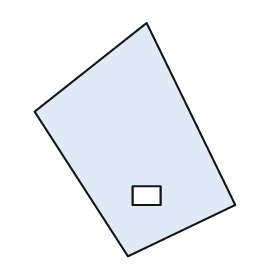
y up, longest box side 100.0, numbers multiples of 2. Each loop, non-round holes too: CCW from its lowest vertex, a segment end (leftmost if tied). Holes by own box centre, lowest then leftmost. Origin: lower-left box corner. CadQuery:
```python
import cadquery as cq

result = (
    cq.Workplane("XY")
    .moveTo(40.0, 0.0)
    .lineTo(86.0, 22.0)
    .lineTo(48.0, 100.0)
    .lineTo(0.0, 62.0)
    .close()
    .moveTo(42.0, 22.0)
    .lineTo(54.0, 22.0)
    .lineTo(54.0, 30.0)
    .lineTo(42.0, 30.0)
    .close()
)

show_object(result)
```